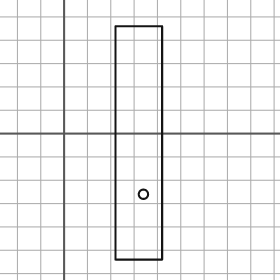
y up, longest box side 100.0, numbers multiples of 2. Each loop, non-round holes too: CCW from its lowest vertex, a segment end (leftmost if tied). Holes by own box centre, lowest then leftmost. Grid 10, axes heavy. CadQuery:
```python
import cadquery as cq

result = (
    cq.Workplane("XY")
    .moveTo(22.0, -54.0)
    .lineTo(42.0, -54.0)
    .lineTo(42.0, 46.0)
    .lineTo(22.0, 46.0)
    .close()
    .moveTo(34.0, -26.0)
    .circle(2.0)
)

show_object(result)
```